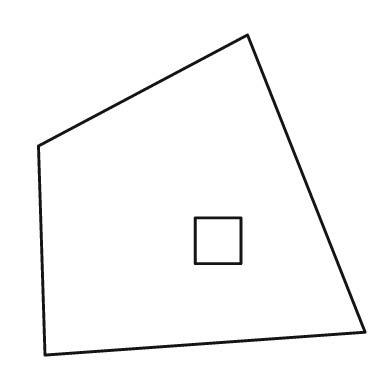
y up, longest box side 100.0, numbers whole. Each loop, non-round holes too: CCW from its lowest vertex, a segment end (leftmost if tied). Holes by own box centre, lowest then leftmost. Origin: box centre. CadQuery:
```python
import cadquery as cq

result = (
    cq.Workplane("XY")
    .moveTo(-48.0, -49.0)
    .lineTo(50.0, -42.0)
    .lineTo(14.0, 49.0)
    .lineTo(-50.0, 15.0)
    .close()
    .moveTo(-2.0, -21.0)
    .lineTo(12.0, -21.0)
    .lineTo(12.0, -7.0)
    .lineTo(-2.0, -7.0)
    .close()
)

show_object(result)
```